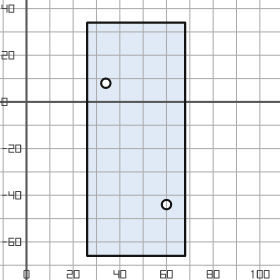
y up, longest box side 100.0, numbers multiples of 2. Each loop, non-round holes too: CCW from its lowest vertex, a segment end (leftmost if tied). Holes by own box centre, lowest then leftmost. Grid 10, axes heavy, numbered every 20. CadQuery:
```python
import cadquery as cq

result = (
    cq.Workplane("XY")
    .moveTo(26.0, -66.0)
    .lineTo(68.0, -66.0)
    .lineTo(68.0, 34.0)
    .lineTo(26.0, 34.0)
    .close()
    .moveTo(60.0, -44.0)
    .circle(2.0)
    .moveTo(34.0, 8.0)
    .circle(2.0)
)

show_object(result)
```